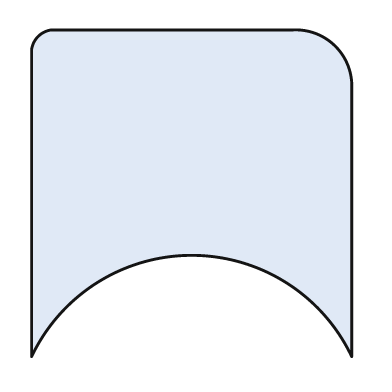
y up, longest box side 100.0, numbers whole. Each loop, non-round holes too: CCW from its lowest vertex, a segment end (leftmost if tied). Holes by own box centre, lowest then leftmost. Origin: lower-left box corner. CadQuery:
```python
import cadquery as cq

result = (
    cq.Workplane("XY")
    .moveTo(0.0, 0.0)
    .threePointArc((49.0, 31.0), (98.0, 0.0))
    .lineTo(98.0, 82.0)
    .threePointArc((93.0, 95.0), (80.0, 100.0))
    .lineTo(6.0, 100.0)
    .threePointArc((2.0, 98.0), (0.0, 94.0))
    .close()
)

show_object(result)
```